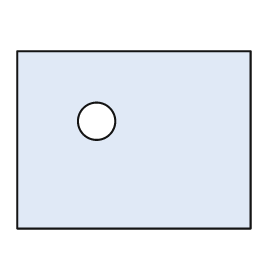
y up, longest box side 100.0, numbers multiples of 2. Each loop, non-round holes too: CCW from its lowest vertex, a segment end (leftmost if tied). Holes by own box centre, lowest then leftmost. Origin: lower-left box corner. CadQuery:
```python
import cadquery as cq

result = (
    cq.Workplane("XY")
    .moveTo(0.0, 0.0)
    .lineTo(100.0, 0.0)
    .lineTo(100.0, 76.0)
    .lineTo(0.0, 76.0)
    .close()
    .moveTo(34.0, 46.0)
    .circle(8.0)
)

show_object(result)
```